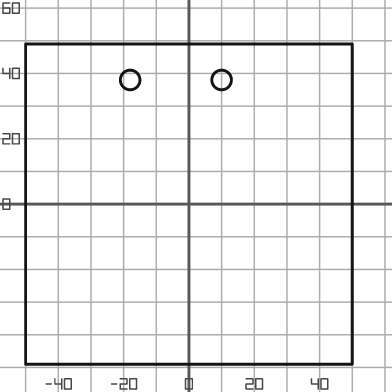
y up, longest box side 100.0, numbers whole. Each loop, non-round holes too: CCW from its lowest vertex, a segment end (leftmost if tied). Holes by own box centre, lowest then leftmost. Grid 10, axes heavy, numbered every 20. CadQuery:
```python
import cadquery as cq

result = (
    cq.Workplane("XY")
    .moveTo(-50.0, -49.0)
    .lineTo(50.0, -49.0)
    .lineTo(50.0, 49.0)
    .lineTo(-50.0, 49.0)
    .close()
    .moveTo(-18.0, 38.0)
    .circle(3.0)
    .moveTo(10.0, 38.0)
    .circle(3.0)
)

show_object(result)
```